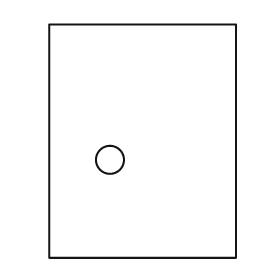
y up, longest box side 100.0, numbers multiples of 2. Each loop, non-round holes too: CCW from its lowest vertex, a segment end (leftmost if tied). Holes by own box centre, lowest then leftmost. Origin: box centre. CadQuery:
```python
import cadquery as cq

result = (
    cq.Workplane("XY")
    .moveTo(-40.0, -50.0)
    .lineTo(40.0, -50.0)
    .lineTo(40.0, 50.0)
    .lineTo(-40.0, 50.0)
    .close()
    .moveTo(-14.0, -8.0)
    .circle(6.0)
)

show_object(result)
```